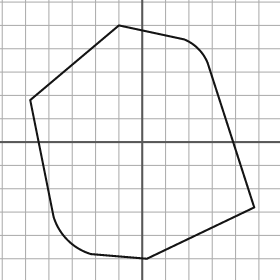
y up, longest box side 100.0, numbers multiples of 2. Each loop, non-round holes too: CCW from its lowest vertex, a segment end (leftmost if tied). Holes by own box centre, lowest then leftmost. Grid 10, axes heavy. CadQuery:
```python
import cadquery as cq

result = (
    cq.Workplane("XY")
    .moveTo(2.0, -50.0)
    .lineTo(48.0, -28.0)
    .lineTo(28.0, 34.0)
    .threePointArc((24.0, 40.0), (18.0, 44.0))
    .lineTo(-10.0, 50.0)
    .lineTo(-48.0, 18.0)
    .lineTo(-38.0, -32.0)
    .threePointArc((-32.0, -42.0), (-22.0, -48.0))
    .close()
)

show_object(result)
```